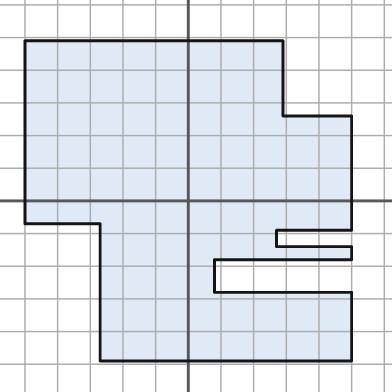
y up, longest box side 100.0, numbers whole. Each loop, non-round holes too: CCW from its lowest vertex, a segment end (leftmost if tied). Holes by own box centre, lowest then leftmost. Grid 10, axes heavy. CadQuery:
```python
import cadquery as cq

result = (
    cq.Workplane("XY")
    .moveTo(-27.0, -49.0)
    .lineTo(50.0, -49.0)
    .lineTo(50.0, -28.0)
    .lineTo(8.0, -28.0)
    .lineTo(8.0, -18.0)
    .lineTo(50.0, -18.0)
    .lineTo(50.0, -14.0)
    .lineTo(27.0, -14.0)
    .lineTo(27.0, -9.0)
    .lineTo(50.0, -9.0)
    .lineTo(50.0, 26.0)
    .lineTo(29.0, 26.0)
    .lineTo(29.0, 49.0)
    .lineTo(-50.0, 49.0)
    .lineTo(-50.0, -7.0)
    .lineTo(-27.0, -7.0)
    .close()
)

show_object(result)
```